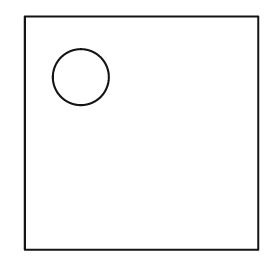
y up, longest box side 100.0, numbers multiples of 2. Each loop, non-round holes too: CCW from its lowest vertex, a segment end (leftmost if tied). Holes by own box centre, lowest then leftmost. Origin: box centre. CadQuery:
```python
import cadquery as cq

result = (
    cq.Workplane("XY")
    .moveTo(-50.0, -50.0)
    .lineTo(50.0, -50.0)
    .lineTo(50.0, 50.0)
    .lineTo(-50.0, 50.0)
    .close()
    .moveTo(-26.0, 24.0)
    .circle(12.0)
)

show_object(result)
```